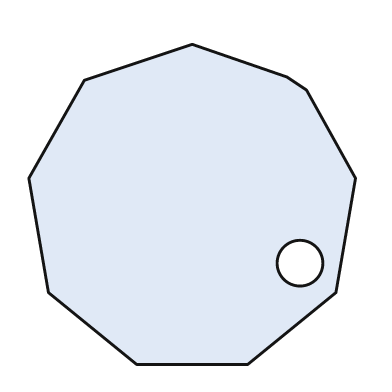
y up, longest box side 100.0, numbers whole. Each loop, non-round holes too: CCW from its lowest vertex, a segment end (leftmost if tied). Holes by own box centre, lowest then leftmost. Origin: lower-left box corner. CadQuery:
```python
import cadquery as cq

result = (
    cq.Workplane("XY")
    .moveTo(33.0, 0.0)
    .lineTo(67.0, 0.0)
    .lineTo(94.0, 22.0)
    .lineTo(100.0, 57.0)
    .lineTo(85.0, 84.0)
    .lineTo(79.0, 88.0)
    .lineTo(50.0, 98.0)
    .lineTo(17.0, 87.0)
    .lineTo(0.0, 57.0)
    .lineTo(6.0, 22.0)
    .close()
    .moveTo(83.0, 31.0)
    .circle(7.0)
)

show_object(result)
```